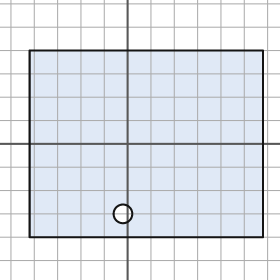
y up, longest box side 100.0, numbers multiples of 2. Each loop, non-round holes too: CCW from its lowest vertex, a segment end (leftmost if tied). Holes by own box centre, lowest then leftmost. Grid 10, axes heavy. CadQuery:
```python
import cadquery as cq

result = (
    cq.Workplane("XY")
    .moveTo(-42.0, -40.0)
    .lineTo(58.0, -40.0)
    .lineTo(58.0, 40.0)
    .lineTo(-42.0, 40.0)
    .close()
    .moveTo(-2.0, -30.0)
    .circle(4.0)
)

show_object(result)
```